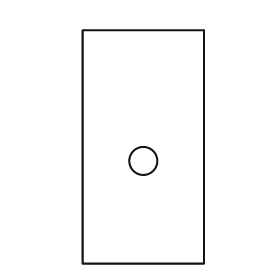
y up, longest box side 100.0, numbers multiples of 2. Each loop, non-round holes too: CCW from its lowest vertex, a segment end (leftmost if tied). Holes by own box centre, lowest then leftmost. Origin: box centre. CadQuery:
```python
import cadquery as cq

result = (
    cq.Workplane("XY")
    .moveTo(-26.0, -50.0)
    .lineTo(26.0, -50.0)
    .lineTo(26.0, 50.0)
    .lineTo(-26.0, 50.0)
    .close()
    .moveTo(0.0, -6.0)
    .circle(6.0)
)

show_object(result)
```